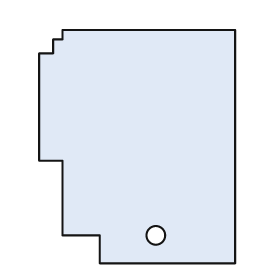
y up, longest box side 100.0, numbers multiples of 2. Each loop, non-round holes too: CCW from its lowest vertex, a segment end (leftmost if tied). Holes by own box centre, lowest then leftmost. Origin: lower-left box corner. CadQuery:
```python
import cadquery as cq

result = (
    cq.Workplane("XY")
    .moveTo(26.0, 0.0)
    .lineTo(84.0, 0.0)
    .lineTo(84.0, 100.0)
    .lineTo(10.0, 100.0)
    .lineTo(10.0, 96.0)
    .lineTo(6.0, 96.0)
    .lineTo(6.0, 90.0)
    .lineTo(0.0, 90.0)
    .lineTo(0.0, 44.0)
    .lineTo(10.0, 44.0)
    .lineTo(10.0, 12.0)
    .lineTo(26.0, 12.0)
    .close()
    .moveTo(50.0, 12.0)
    .circle(4.0)
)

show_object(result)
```